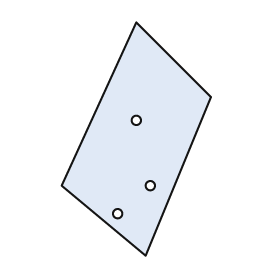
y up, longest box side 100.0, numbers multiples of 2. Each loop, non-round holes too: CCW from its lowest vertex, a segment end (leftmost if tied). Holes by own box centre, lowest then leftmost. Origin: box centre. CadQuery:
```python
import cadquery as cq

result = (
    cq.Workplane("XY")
    .moveTo(4.0, -50.0)
    .lineTo(32.0, 18.0)
    .lineTo(0.0, 50.0)
    .lineTo(-32.0, -20.0)
    .close()
    .moveTo(-8.0, -32.0)
    .circle(2.0)
    .moveTo(6.0, -20.0)
    .circle(2.0)
    .moveTo(0.0, 8.0)
    .circle(2.0)
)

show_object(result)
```